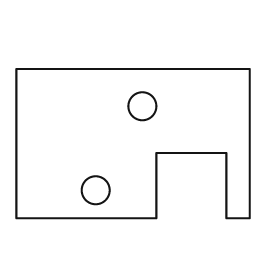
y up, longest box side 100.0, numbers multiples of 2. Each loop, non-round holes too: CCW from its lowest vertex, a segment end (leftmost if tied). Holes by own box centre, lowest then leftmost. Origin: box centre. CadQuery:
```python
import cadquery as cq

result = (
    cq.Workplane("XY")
    .moveTo(-50.0, -32.0)
    .lineTo(10.0, -32.0)
    .lineTo(10.0, -4.0)
    .lineTo(40.0, -4.0)
    .lineTo(40.0, -32.0)
    .lineTo(50.0, -32.0)
    .lineTo(50.0, 32.0)
    .lineTo(-50.0, 32.0)
    .close()
    .moveTo(-16.0, -20.0)
    .circle(6.0)
    .moveTo(4.0, 16.0)
    .circle(6.0)
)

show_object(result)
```